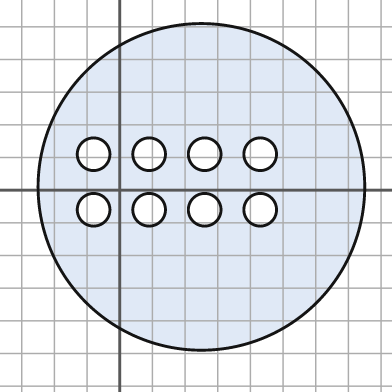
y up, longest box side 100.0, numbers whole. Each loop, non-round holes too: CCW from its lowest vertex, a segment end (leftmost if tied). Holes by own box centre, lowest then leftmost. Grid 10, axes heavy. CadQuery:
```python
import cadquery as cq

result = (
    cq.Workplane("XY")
    .moveTo(25.0, 1.0)
    .circle(50.0)
    .moveTo(-8.0, -6.0)
    .circle(5.0)
    .moveTo(9.0, -6.0)
    .circle(5.0)
    .moveTo(26.0, -6.0)
    .circle(5.0)
    .moveTo(43.0, -6.0)
    .circle(5.0)
    .moveTo(-8.0, 11.0)
    .circle(5.0)
    .moveTo(9.0, 11.0)
    .circle(5.0)
    .moveTo(26.0, 11.0)
    .circle(5.0)
    .moveTo(43.0, 11.0)
    .circle(5.0)
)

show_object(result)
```